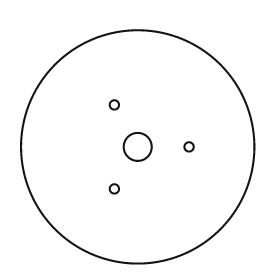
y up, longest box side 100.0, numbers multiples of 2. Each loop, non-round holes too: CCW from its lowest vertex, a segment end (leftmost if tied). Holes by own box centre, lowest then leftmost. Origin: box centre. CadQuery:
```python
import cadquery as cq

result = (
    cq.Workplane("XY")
    .moveTo(0.0, 0.0)
    .circle(50.0)
    .moveTo(-10.0, -18.0)
    .circle(2.0)
    .moveTo(0.0, 0.0)
    .circle(6.0)
    .moveTo(22.0, 0.0)
    .circle(2.0)
    .moveTo(-10.0, 18.0)
    .circle(2.0)
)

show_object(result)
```